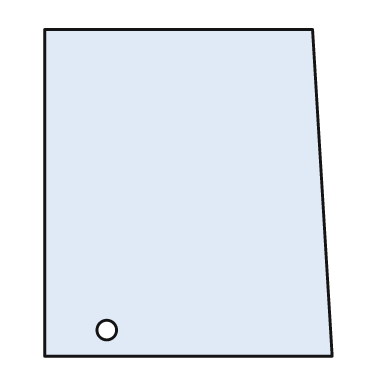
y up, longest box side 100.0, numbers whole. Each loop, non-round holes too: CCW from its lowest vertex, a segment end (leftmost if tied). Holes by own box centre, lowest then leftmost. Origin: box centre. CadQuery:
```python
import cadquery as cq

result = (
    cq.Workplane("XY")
    .moveTo(-44.0, -50.0)
    .lineTo(44.0, -50.0)
    .lineTo(38.0, 50.0)
    .lineTo(-44.0, 50.0)
    .close()
    .moveTo(-25.0, -42.0)
    .circle(3.0)
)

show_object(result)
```